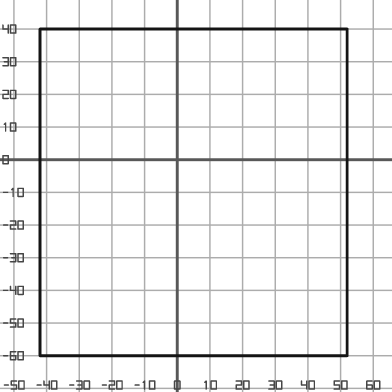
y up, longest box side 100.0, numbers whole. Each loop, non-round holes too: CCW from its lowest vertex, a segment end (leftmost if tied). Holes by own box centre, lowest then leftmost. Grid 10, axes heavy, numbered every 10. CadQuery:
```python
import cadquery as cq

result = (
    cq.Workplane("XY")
    .moveTo(-42.0, -60.0)
    .lineTo(52.0, -60.0)
    .lineTo(52.0, 40.0)
    .lineTo(-42.0, 40.0)
    .close()
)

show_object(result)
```